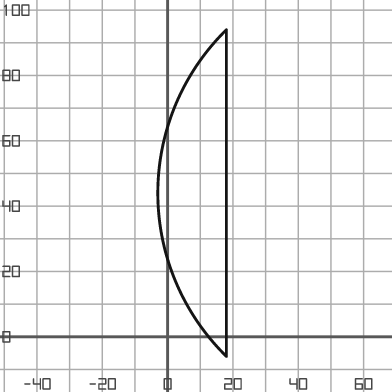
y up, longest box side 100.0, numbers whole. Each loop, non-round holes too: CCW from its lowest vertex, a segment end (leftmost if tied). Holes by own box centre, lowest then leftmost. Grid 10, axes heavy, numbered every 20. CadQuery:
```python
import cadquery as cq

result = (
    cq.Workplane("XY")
    .moveTo(18.0, -6.0)
    .lineTo(18.0, 94.0)
    .threePointArc((-3.0, 44.0), (18.0, -6.0))
    .close()
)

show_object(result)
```